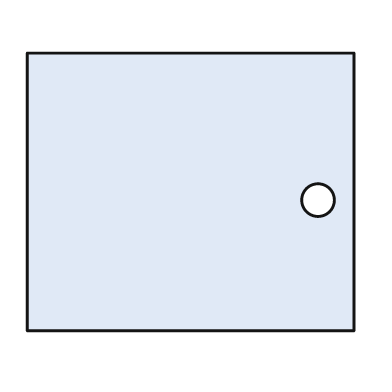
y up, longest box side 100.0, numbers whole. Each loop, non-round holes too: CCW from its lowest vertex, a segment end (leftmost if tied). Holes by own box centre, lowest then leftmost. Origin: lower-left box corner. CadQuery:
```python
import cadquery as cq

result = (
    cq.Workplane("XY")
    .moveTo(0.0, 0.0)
    .lineTo(100.0, 0.0)
    .lineTo(100.0, 85.0)
    .lineTo(0.0, 85.0)
    .close()
    .moveTo(89.0, 40.0)
    .circle(5.0)
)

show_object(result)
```